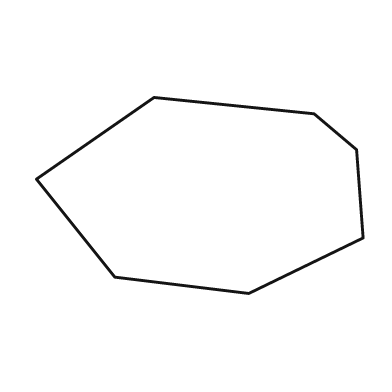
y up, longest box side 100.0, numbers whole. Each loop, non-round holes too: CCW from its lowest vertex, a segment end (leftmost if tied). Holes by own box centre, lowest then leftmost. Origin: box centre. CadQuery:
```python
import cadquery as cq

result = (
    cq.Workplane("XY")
    .moveTo(15.0, -30.0)
    .lineTo(50.0, -13.0)
    .lineTo(48.0, 14.0)
    .lineTo(35.0, 25.0)
    .lineTo(-14.0, 30.0)
    .lineTo(-50.0, 5.0)
    .lineTo(-26.0, -25.0)
    .close()
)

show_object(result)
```